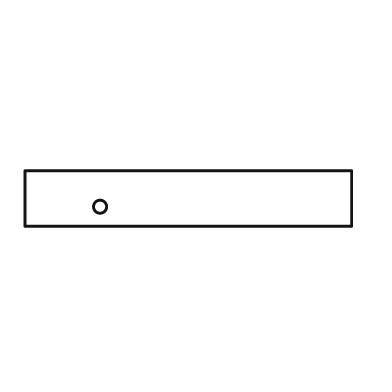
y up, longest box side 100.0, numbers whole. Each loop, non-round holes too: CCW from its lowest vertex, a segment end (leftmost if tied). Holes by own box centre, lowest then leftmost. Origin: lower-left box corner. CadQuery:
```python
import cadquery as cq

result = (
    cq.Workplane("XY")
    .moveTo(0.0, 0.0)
    .lineTo(100.0, 0.0)
    .lineTo(100.0, 17.0)
    .lineTo(0.0, 17.0)
    .close()
    .moveTo(23.0, 6.0)
    .circle(2.0)
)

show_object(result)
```